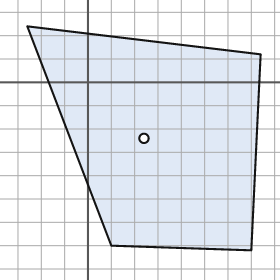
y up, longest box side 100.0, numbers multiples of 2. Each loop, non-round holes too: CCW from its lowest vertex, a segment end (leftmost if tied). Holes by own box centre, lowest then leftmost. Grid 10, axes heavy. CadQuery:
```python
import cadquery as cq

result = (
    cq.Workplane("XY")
    .moveTo(70.0, -72.0)
    .lineTo(74.0, 12.0)
    .lineTo(-26.0, 24.0)
    .lineTo(10.0, -70.0)
    .close()
    .moveTo(24.0, -24.0)
    .circle(2.0)
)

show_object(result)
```